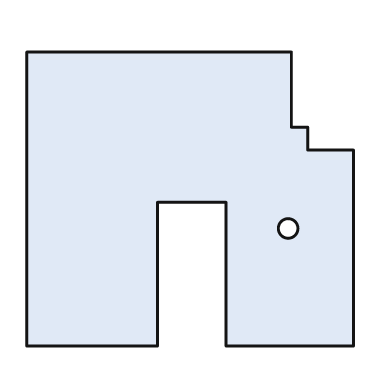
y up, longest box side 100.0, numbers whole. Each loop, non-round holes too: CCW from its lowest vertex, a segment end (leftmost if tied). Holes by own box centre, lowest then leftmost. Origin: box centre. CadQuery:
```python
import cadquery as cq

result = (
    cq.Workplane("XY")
    .moveTo(-50.0, -45.0)
    .lineTo(-10.0, -45.0)
    .lineTo(-10.0, -1.0)
    .lineTo(11.0, -1.0)
    .lineTo(11.0, -45.0)
    .lineTo(50.0, -45.0)
    .lineTo(50.0, 15.0)
    .lineTo(36.0, 15.0)
    .lineTo(36.0, 22.0)
    .lineTo(31.0, 22.0)
    .lineTo(31.0, 45.0)
    .lineTo(-50.0, 45.0)
    .close()
    .moveTo(30.0, -9.0)
    .circle(3.0)
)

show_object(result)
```